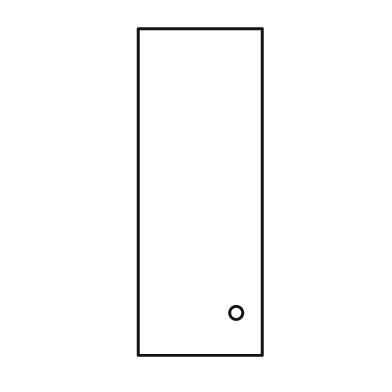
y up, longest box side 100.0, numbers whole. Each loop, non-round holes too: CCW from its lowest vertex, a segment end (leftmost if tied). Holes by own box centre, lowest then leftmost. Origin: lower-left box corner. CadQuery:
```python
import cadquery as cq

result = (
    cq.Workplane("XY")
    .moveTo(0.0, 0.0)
    .lineTo(38.0, 0.0)
    .lineTo(38.0, 100.0)
    .lineTo(0.0, 100.0)
    .close()
    .moveTo(30.0, 13.0)
    .circle(2.0)
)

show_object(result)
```